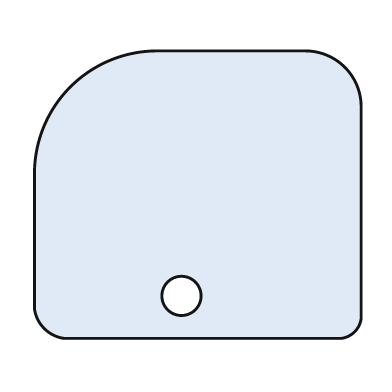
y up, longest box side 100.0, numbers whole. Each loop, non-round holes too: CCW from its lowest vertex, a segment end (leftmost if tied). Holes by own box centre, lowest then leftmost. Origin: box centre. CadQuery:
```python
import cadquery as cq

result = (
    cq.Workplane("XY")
    .moveTo(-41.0, -44.0)
    .lineTo(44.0, -44.0)
    .threePointArc((48.0, -42.0), (50.0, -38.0))
    .lineTo(50.0, 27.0)
    .threePointArc((45.0, 39.0), (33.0, 44.0))
    .lineTo(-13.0, 44.0)
    .threePointArc((-39.0, 33.0), (-50.0, 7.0))
    .lineTo(-50.0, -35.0)
    .threePointArc((-47.0, -41.0), (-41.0, -44.0))
    .close()
    .moveTo(-5.0, -31.0)
    .circle(6.0)
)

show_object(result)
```